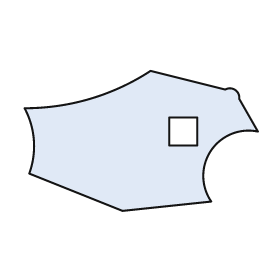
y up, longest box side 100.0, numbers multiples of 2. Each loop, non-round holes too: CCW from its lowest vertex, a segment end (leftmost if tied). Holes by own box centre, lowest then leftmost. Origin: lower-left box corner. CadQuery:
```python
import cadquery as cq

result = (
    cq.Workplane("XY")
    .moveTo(42.0, 0.0)
    .lineTo(80.0, 4.0)
    .threePointArc((80.0, 26.0), (100.0, 34.0))
    .lineTo(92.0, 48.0)
    .threePointArc((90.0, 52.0), (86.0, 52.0))
    .lineTo(54.0, 60.0)
    .threePointArc((28.0, 48.0), (0.0, 44.0))
    .threePointArc((4.0, 30.0), (2.0, 16.0))
    .close()
    .moveTo(62.0, 28.0)
    .lineTo(74.0, 28.0)
    .lineTo(74.0, 40.0)
    .lineTo(62.0, 40.0)
    .close()
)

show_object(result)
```